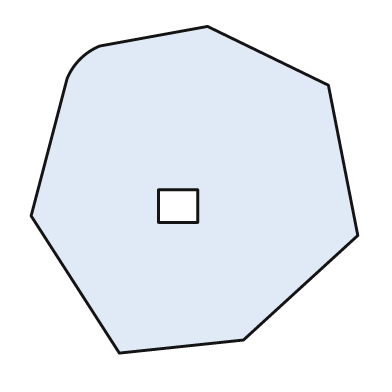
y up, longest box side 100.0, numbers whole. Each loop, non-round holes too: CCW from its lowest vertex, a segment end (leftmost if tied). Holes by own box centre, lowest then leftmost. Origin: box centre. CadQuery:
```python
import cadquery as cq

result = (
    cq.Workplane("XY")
    .moveTo(-23.0, -50.0)
    .lineTo(15.0, -46.0)
    .lineTo(50.0, -14.0)
    .lineTo(41.0, 32.0)
    .lineTo(4.0, 50.0)
    .lineTo(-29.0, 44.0)
    .threePointArc((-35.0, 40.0), (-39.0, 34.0))
    .lineTo(-50.0, -8.0)
    .close()
    .moveTo(-11.0, -10.0)
    .lineTo(1.0, -10.0)
    .lineTo(1.0, 0.0)
    .lineTo(-11.0, 0.0)
    .close()
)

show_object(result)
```